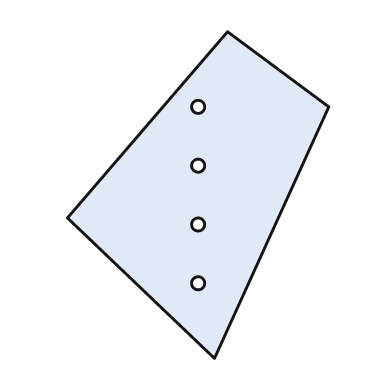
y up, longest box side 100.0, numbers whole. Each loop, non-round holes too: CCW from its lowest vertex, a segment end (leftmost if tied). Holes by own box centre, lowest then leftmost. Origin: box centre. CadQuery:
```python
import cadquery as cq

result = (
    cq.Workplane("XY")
    .moveTo(5.0, -50.0)
    .lineTo(40.0, 27.0)
    .lineTo(9.0, 50.0)
    .lineTo(-40.0, -7.0)
    .close()
    .moveTo(0.0, -27.0)
    .circle(2.0)
    .moveTo(0.0, -9.0)
    .circle(2.0)
    .moveTo(0.0, 9.0)
    .circle(2.0)
    .moveTo(0.0, 27.0)
    .circle(2.0)
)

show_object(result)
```